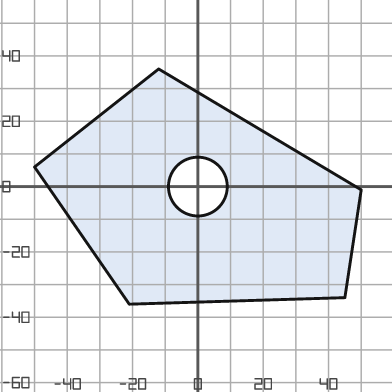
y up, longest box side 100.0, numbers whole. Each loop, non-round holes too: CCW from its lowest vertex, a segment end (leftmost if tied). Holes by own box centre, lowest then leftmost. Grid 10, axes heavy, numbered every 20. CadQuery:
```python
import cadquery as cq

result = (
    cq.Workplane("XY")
    .moveTo(-21.0, -36.0)
    .lineTo(45.0, -34.0)
    .lineTo(50.0, -1.0)
    .lineTo(-12.0, 36.0)
    .lineTo(-50.0, 6.0)
    .close()
    .moveTo(0.0, 0.0)
    .circle(9.0)
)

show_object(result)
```